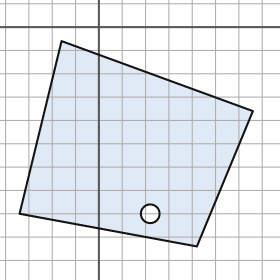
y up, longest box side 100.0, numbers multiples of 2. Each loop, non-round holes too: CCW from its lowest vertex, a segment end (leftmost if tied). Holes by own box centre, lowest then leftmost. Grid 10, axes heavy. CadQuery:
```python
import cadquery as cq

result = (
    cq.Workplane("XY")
    .moveTo(42.0, -94.0)
    .lineTo(66.0, -36.0)
    .lineTo(-16.0, -6.0)
    .lineTo(-34.0, -80.0)
    .close()
    .moveTo(22.0, -80.0)
    .circle(4.0)
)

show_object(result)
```